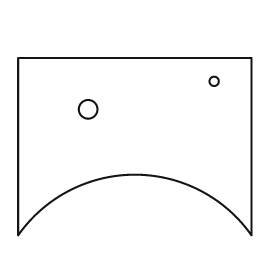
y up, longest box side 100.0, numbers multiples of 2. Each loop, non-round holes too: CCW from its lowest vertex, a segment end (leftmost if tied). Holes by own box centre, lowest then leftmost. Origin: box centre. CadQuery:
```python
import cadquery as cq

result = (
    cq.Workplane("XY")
    .moveTo(-50.0, -38.0)
    .threePointArc((0.0, -12.0), (50.0, -38.0))
    .lineTo(50.0, 38.0)
    .lineTo(-50.0, 38.0)
    .close()
    .moveTo(-20.0, 16.0)
    .circle(4.0)
    .moveTo(34.0, 28.0)
    .circle(2.0)
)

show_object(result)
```